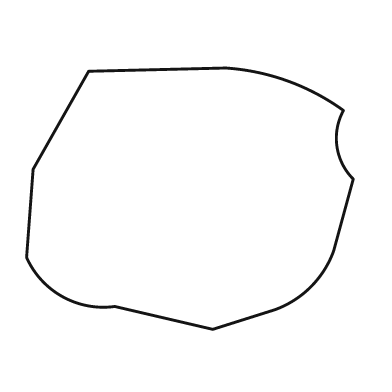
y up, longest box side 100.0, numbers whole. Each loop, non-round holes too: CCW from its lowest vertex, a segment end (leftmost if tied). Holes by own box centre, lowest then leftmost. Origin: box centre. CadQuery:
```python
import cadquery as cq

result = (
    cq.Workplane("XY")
    .moveTo(7.0, -40.0)
    .lineTo(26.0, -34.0)
    .threePointArc((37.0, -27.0), (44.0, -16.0))
    .lineTo(50.0, 6.0)
    .threePointArc((45.0, 16.0), (47.0, 27.0))
    .threePointArc((30.0, 36.0), (11.0, 40.0))
    .lineTo(-31.0, 39.0)
    .lineTo(-48.0, 9.0)
    .lineTo(-50.0, -18.0)
    .threePointArc((-39.0, -30.0), (-23.0, -33.0))
    .close()
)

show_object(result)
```